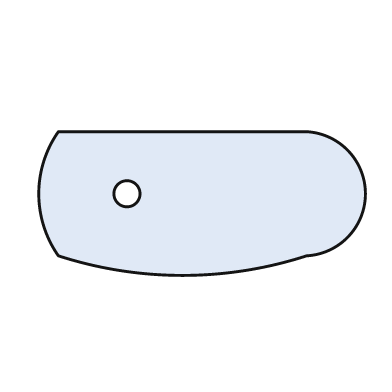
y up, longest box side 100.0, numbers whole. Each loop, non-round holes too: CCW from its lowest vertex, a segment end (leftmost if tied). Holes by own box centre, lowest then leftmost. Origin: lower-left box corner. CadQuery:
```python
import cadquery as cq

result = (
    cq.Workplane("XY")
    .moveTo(6.0, 6.0)
    .threePointArc((44.0, 0.0), (82.0, 6.0))
    .threePointArc((100.0, 25.0), (82.0, 44.0))
    .lineTo(6.0, 44.0)
    .threePointArc((0.0, 25.0), (6.0, 6.0))
    .close()
    .moveTo(27.0, 25.0)
    .circle(4.0)
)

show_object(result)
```